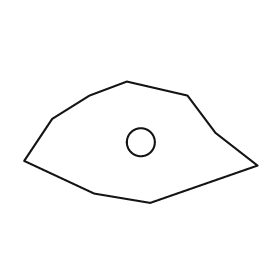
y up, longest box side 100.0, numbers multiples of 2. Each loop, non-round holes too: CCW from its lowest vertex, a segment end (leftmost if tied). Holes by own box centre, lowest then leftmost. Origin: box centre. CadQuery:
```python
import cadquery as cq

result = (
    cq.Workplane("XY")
    .moveTo(4.0, -26.0)
    .lineTo(50.0, -10.0)
    .lineTo(32.0, 4.0)
    .lineTo(20.0, 20.0)
    .lineTo(-6.0, 26.0)
    .lineTo(-22.0, 20.0)
    .lineTo(-38.0, 10.0)
    .lineTo(-50.0, -8.0)
    .lineTo(-20.0, -22.0)
    .close()
    .moveTo(0.0, 0.0)
    .circle(6.0)
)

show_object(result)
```